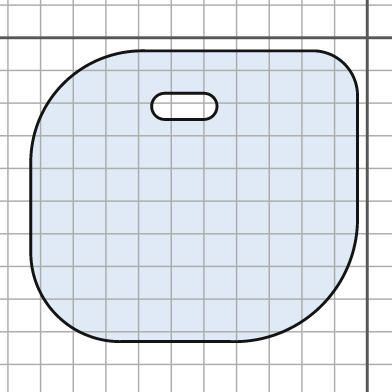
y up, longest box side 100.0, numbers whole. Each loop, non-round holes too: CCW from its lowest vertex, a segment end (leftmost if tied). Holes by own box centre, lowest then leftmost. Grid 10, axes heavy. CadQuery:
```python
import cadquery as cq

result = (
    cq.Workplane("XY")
    .moveTo(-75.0, -93.0)
    .lineTo(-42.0, -93.0)
    .threePointArc((-14.0, -82.0), (-3.0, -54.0))
    .lineTo(-3.0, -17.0)
    .threePointArc((-7.0, -8.0), (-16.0, -4.0))
    .lineTo(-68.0, -4.0)
    .threePointArc((-93.0, -14.0), (-103.0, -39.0))
    .lineTo(-103.0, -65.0)
    .threePointArc((-95.0, -85.0), (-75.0, -93.0))
    .close()
    .moveTo(-62.0, -25.0)
    .lineTo(-50.0, -25.0)
    .threePointArc((-46.0, -21.0), (-50.0, -17.0))
    .lineTo(-62.0, -17.0)
    .threePointArc((-66.0, -21.0), (-62.0, -25.0))
    .close()
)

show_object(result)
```